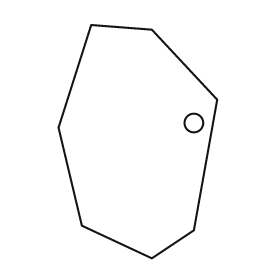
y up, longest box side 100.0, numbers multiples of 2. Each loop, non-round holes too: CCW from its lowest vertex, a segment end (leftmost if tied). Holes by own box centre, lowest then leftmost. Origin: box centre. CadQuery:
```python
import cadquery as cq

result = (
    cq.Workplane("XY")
    .moveTo(6.0, -50.0)
    .lineTo(24.0, -38.0)
    .lineTo(34.0, 18.0)
    .lineTo(6.0, 48.0)
    .lineTo(-20.0, 50.0)
    .lineTo(-34.0, 6.0)
    .lineTo(-24.0, -36.0)
    .close()
    .moveTo(24.0, 8.0)
    .circle(4.0)
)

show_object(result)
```